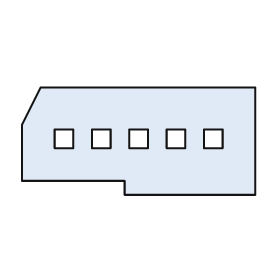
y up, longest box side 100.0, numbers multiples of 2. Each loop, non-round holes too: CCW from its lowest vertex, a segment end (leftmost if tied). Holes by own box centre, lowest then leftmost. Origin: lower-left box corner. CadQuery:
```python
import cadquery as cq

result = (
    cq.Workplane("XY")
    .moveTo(44.0, 0.0)
    .lineTo(100.0, 0.0)
    .lineTo(100.0, 46.0)
    .lineTo(8.0, 46.0)
    .lineTo(0.0, 30.0)
    .lineTo(0.0, 6.0)
    .lineTo(44.0, 6.0)
    .close()
    .moveTo(14.0, 20.0)
    .lineTo(22.0, 20.0)
    .lineTo(22.0, 28.0)
    .lineTo(14.0, 28.0)
    .close()
    .moveTo(30.0, 20.0)
    .lineTo(38.0, 20.0)
    .lineTo(38.0, 28.0)
    .lineTo(30.0, 28.0)
    .close()
    .moveTo(46.0, 20.0)
    .lineTo(54.0, 20.0)
    .lineTo(54.0, 28.0)
    .lineTo(46.0, 28.0)
    .close()
    .moveTo(62.0, 20.0)
    .lineTo(70.0, 20.0)
    .lineTo(70.0, 28.0)
    .lineTo(62.0, 28.0)
    .close()
    .moveTo(78.0, 20.0)
    .lineTo(86.0, 20.0)
    .lineTo(86.0, 28.0)
    .lineTo(78.0, 28.0)
    .close()
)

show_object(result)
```